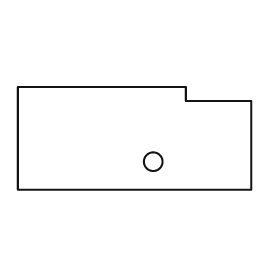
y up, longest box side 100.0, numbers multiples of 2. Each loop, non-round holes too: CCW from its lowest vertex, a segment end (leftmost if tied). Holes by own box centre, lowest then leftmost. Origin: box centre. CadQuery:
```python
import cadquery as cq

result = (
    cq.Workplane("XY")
    .moveTo(-50.0, -22.0)
    .lineTo(50.0, -22.0)
    .lineTo(50.0, 16.0)
    .lineTo(22.0, 16.0)
    .lineTo(22.0, 22.0)
    .lineTo(-50.0, 22.0)
    .close()
    .moveTo(8.0, -10.0)
    .circle(4.0)
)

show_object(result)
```